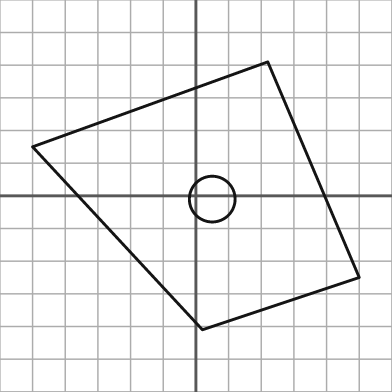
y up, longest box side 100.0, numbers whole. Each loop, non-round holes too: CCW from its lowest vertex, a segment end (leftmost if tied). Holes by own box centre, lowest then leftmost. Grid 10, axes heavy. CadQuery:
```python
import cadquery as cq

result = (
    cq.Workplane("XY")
    .moveTo(2.0, -41.0)
    .lineTo(50.0, -25.0)
    .lineTo(22.0, 41.0)
    .lineTo(-50.0, 15.0)
    .close()
    .moveTo(5.0, -1.0)
    .circle(7.0)
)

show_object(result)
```